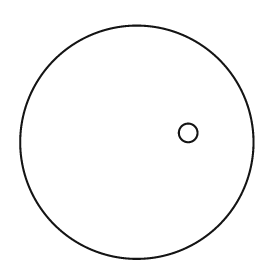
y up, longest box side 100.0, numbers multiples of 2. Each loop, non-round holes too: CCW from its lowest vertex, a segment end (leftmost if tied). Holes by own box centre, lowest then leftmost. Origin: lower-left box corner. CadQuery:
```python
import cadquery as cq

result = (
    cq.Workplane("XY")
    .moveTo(50.0, 50.0)
    .circle(50.0)
    .moveTo(72.0, 54.0)
    .circle(4.0)
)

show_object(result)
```